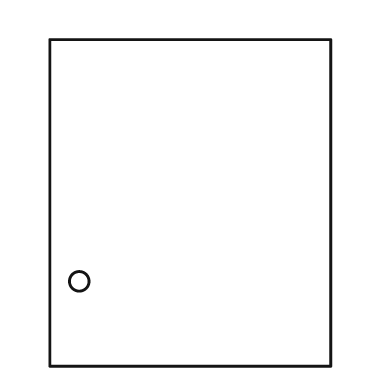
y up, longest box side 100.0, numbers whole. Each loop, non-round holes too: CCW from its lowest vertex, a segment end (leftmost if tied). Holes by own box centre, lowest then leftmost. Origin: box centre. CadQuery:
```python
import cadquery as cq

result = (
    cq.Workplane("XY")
    .moveTo(-43.0, -50.0)
    .lineTo(43.0, -50.0)
    .lineTo(43.0, 50.0)
    .lineTo(-43.0, 50.0)
    .close()
    .moveTo(-34.0, -24.0)
    .circle(3.0)
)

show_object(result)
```